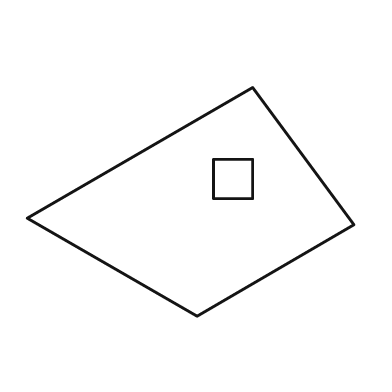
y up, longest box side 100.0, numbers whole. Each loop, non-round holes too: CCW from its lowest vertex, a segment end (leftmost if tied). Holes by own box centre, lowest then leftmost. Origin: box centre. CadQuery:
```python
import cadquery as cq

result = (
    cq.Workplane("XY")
    .moveTo(2.0, -35.0)
    .lineTo(50.0, -7.0)
    .lineTo(19.0, 35.0)
    .lineTo(-50.0, -5.0)
    .close()
    .moveTo(7.0, 1.0)
    .lineTo(19.0, 1.0)
    .lineTo(19.0, 13.0)
    .lineTo(7.0, 13.0)
    .close()
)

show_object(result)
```